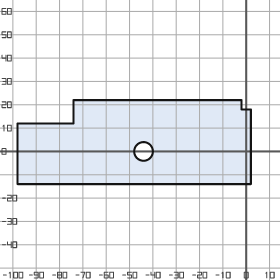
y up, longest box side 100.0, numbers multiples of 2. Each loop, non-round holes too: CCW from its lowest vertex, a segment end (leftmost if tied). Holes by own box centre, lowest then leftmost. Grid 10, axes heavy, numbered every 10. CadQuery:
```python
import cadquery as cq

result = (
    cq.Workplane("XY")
    .moveTo(-98.0, -14.0)
    .lineTo(2.0, -14.0)
    .lineTo(2.0, 18.0)
    .lineTo(-2.0, 18.0)
    .lineTo(-2.0, 22.0)
    .lineTo(-74.0, 22.0)
    .lineTo(-74.0, 12.0)
    .lineTo(-98.0, 12.0)
    .close()
    .moveTo(-44.0, 0.0)
    .circle(4.0)
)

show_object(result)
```